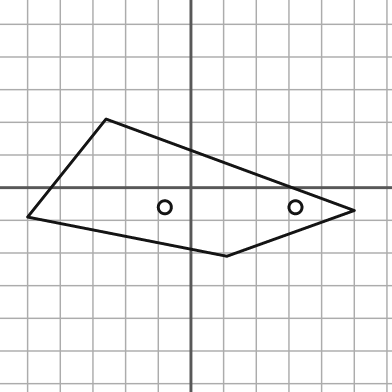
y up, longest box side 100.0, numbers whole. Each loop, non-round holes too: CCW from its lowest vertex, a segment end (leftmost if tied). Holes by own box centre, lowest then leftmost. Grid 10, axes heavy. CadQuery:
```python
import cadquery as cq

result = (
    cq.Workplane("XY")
    .moveTo(11.0, -21.0)
    .lineTo(50.0, -7.0)
    .lineTo(-26.0, 21.0)
    .lineTo(-50.0, -9.0)
    .close()
    .moveTo(-8.0, -6.0)
    .circle(2.0)
    .moveTo(32.0, -6.0)
    .circle(2.0)
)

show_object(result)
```